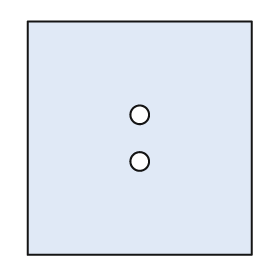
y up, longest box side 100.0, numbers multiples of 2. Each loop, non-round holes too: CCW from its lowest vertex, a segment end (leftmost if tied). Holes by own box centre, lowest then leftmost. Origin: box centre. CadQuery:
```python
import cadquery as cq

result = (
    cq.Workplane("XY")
    .moveTo(-48.0, -50.0)
    .lineTo(48.0, -50.0)
    .lineTo(48.0, 50.0)
    .lineTo(-48.0, 50.0)
    .close()
    .moveTo(0.0, -10.0)
    .circle(4.0)
    .moveTo(0.0, 10.0)
    .circle(4.0)
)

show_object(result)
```